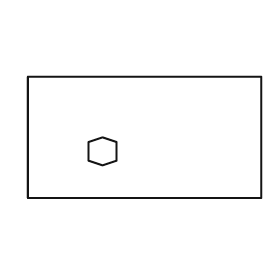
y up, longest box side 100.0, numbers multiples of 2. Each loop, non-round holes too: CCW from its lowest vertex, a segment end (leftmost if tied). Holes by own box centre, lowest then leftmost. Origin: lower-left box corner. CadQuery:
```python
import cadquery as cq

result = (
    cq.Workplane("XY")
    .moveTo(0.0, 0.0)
    .lineTo(100.0, 0.0)
    .lineTo(100.0, 52.0)
    .lineTo(0.0, 52.0)
    .close()
    .moveTo(32.0, 14.0)
    .lineTo(38.0, 16.0)
    .lineTo(38.0, 24.0)
    .lineTo(32.0, 26.0)
    .lineTo(26.0, 24.0)
    .lineTo(26.0, 16.0)
    .close()
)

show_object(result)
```